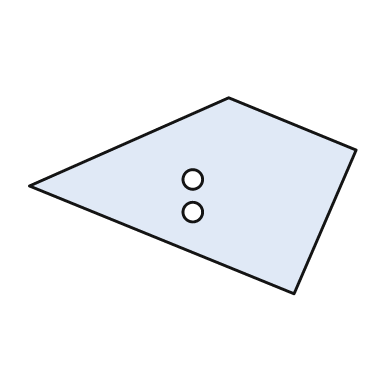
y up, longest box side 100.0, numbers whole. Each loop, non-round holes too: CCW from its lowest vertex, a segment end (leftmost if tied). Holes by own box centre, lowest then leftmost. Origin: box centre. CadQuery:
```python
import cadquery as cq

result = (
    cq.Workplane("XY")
    .moveTo(31.0, -30.0)
    .lineTo(50.0, 14.0)
    .lineTo(11.0, 30.0)
    .lineTo(-50.0, 3.0)
    .close()
    .moveTo(0.0, -5.0)
    .circle(3.0)
    .moveTo(0.0, 5.0)
    .circle(3.0)
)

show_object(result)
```